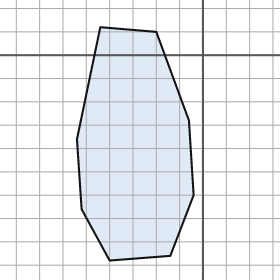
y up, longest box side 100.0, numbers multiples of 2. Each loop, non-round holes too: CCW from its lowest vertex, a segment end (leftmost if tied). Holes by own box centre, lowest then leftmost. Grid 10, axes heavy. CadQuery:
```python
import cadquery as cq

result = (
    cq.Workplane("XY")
    .moveTo(-40.0, -88.0)
    .lineTo(-14.0, -86.0)
    .lineTo(-4.0, -60.0)
    .lineTo(-6.0, -28.0)
    .lineTo(-20.0, 10.0)
    .lineTo(-44.0, 12.0)
    .lineTo(-54.0, -36.0)
    .lineTo(-52.0, -66.0)
    .close()
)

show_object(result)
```